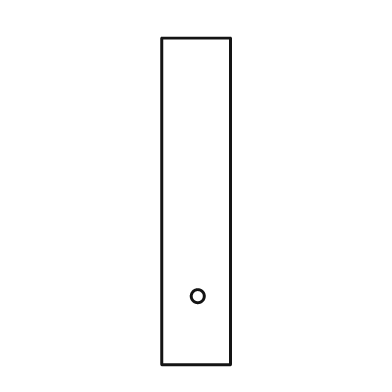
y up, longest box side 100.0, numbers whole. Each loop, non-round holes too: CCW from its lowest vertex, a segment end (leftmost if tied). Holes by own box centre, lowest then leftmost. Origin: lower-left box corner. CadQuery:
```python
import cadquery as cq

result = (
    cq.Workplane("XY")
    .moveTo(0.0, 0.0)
    .lineTo(21.0, 0.0)
    .lineTo(21.0, 100.0)
    .lineTo(0.0, 100.0)
    .close()
    .moveTo(11.0, 21.0)
    .circle(2.0)
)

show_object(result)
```